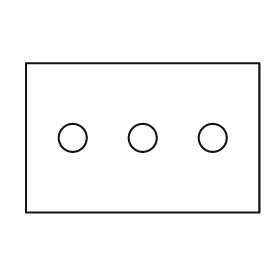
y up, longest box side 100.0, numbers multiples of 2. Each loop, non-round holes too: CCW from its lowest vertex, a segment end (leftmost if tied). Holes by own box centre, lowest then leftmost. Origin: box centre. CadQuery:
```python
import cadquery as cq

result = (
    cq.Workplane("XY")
    .moveTo(-50.0, -32.0)
    .lineTo(50.0, -32.0)
    .lineTo(50.0, 32.0)
    .lineTo(-50.0, 32.0)
    .close()
    .moveTo(-30.0, 0.0)
    .circle(6.0)
    .moveTo(0.0, 0.0)
    .circle(6.0)
    .moveTo(30.0, 0.0)
    .circle(6.0)
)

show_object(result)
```